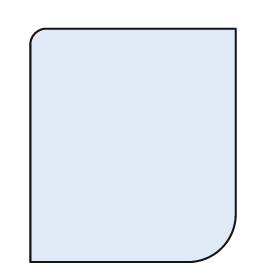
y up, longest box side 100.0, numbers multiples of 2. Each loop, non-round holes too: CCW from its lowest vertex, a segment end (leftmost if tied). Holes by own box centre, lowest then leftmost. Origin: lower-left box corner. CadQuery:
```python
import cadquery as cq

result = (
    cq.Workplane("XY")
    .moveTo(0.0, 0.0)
    .lineTo(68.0, 0.0)
    .threePointArc((82.0, 6.0), (88.0, 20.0))
    .lineTo(88.0, 100.0)
    .lineTo(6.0, 100.0)
    .threePointArc((2.0, 98.0), (0.0, 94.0))
    .close()
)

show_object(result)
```